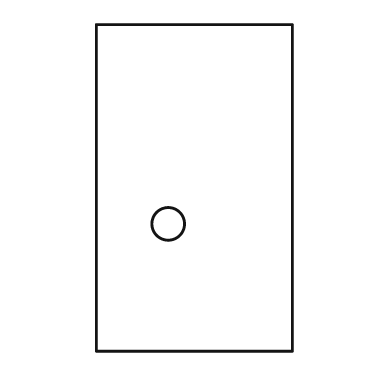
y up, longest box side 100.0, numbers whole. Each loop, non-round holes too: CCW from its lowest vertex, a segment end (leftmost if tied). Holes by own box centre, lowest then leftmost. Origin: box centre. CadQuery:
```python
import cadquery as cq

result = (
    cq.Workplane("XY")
    .moveTo(-30.0, -50.0)
    .lineTo(30.0, -50.0)
    .lineTo(30.0, 50.0)
    .lineTo(-30.0, 50.0)
    .close()
    .moveTo(-8.0, -11.0)
    .circle(5.0)
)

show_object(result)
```